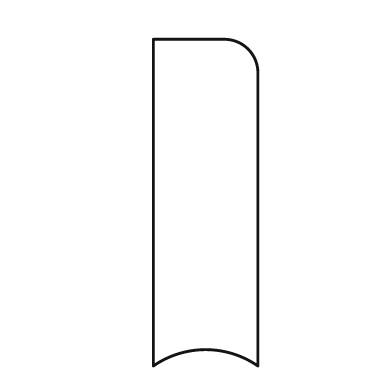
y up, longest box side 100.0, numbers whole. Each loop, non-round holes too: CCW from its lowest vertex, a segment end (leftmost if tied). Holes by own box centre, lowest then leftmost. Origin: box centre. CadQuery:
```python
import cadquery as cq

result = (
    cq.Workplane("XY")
    .moveTo(-16.0, -50.0)
    .threePointArc((0.0, -45.0), (16.0, -50.0))
    .lineTo(16.0, 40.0)
    .threePointArc((13.0, 47.0), (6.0, 50.0))
    .lineTo(-16.0, 50.0)
    .close()
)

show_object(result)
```